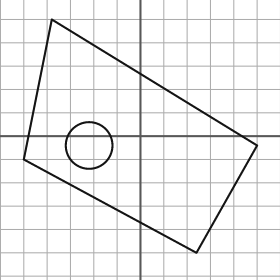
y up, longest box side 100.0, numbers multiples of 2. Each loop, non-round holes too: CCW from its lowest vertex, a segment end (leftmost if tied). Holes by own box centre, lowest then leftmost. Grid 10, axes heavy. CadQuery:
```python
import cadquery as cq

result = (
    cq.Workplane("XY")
    .moveTo(24.0, -50.0)
    .lineTo(50.0, -4.0)
    .lineTo(-38.0, 50.0)
    .lineTo(-50.0, -10.0)
    .close()
    .moveTo(-22.0, -4.0)
    .circle(10.0)
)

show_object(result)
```